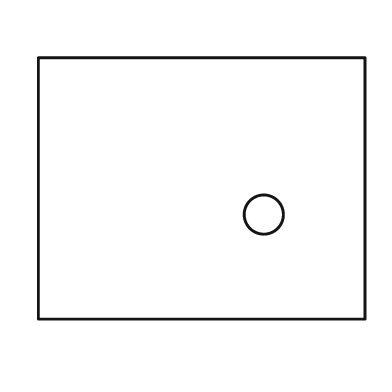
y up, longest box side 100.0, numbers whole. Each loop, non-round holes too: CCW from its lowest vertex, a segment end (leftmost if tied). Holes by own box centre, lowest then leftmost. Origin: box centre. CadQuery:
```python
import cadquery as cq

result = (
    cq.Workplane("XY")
    .moveTo(-50.0, -40.0)
    .lineTo(50.0, -40.0)
    .lineTo(50.0, 40.0)
    .lineTo(-50.0, 40.0)
    .close()
    .moveTo(19.0, -8.0)
    .circle(6.0)
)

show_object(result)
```